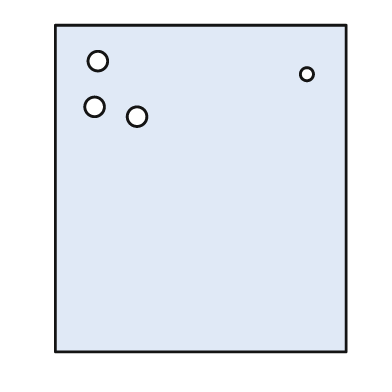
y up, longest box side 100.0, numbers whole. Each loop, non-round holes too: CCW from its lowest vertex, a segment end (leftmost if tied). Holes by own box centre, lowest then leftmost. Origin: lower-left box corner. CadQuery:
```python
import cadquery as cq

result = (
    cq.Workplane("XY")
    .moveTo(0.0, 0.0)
    .lineTo(89.0, 0.0)
    .lineTo(89.0, 100.0)
    .lineTo(0.0, 100.0)
    .close()
    .moveTo(25.0, 72.0)
    .circle(3.0)
    .moveTo(12.0, 75.0)
    .circle(3.0)
    .moveTo(77.0, 85.0)
    .circle(2.0)
    .moveTo(13.0, 89.0)
    .circle(3.0)
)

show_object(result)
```